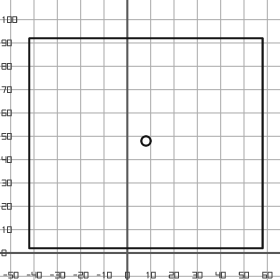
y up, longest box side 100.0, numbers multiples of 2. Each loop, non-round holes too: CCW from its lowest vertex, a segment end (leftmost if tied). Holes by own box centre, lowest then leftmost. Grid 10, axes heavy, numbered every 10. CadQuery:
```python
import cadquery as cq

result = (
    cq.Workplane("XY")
    .moveTo(-42.0, 2.0)
    .lineTo(58.0, 2.0)
    .lineTo(58.0, 92.0)
    .lineTo(-42.0, 92.0)
    .close()
    .moveTo(8.0, 48.0)
    .circle(2.0)
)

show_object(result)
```